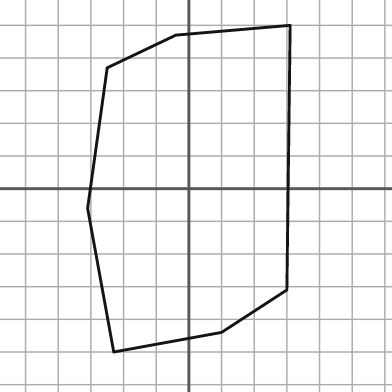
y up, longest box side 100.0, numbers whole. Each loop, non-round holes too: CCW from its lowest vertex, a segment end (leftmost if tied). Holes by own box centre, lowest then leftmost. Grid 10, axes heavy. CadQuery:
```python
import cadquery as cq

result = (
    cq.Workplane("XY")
    .moveTo(-23.0, -50.0)
    .lineTo(10.0, -44.0)
    .lineTo(30.0, -31.0)
    .lineTo(31.0, 50.0)
    .lineTo(-4.0, 47.0)
    .lineTo(-25.0, 37.0)
    .lineTo(-31.0, -6.0)
    .close()
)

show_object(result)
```